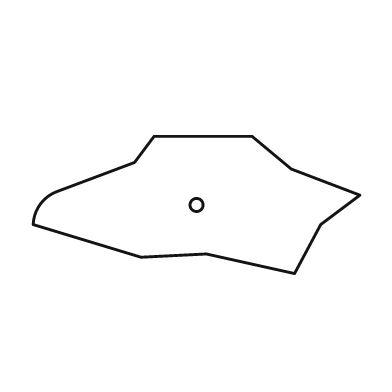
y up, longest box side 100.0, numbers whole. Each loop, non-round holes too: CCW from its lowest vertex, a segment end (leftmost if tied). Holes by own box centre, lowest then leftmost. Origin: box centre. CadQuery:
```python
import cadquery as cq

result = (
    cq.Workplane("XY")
    .moveTo(30.0, -21.0)
    .lineTo(38.0, -6.0)
    .lineTo(50.0, 3.0)
    .lineTo(29.0, 11.0)
    .lineTo(17.0, 21.0)
    .lineTo(-13.0, 21.0)
    .lineTo(-19.0, 13.0)
    .lineTo(-43.0, 4.0)
    .threePointArc((-48.0, 0.0), (-50.0, -6.0))
    .lineTo(-17.0, -16.0)
    .lineTo(3.0, -15.0)
    .close()
    .moveTo(0.0, 0.0)
    .circle(2.0)
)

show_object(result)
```